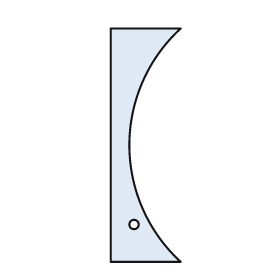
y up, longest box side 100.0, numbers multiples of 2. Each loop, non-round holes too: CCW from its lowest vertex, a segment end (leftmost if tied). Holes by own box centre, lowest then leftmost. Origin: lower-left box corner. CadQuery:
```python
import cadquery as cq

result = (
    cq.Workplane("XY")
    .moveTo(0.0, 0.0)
    .lineTo(30.0, 0.0)
    .threePointArc((8.0, 50.0), (30.0, 100.0))
    .lineTo(0.0, 100.0)
    .close()
    .moveTo(10.0, 16.0)
    .circle(2.0)
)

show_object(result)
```